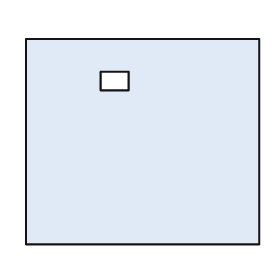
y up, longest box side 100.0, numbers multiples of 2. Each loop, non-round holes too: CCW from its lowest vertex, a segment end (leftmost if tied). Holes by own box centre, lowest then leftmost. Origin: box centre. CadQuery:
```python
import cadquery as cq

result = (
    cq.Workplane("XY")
    .moveTo(-50.0, -44.0)
    .lineTo(50.0, -44.0)
    .lineTo(50.0, 44.0)
    .lineTo(-50.0, 44.0)
    .close()
    .moveTo(-18.0, 22.0)
    .lineTo(-6.0, 22.0)
    .lineTo(-6.0, 30.0)
    .lineTo(-18.0, 30.0)
    .close()
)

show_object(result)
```